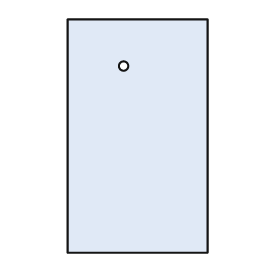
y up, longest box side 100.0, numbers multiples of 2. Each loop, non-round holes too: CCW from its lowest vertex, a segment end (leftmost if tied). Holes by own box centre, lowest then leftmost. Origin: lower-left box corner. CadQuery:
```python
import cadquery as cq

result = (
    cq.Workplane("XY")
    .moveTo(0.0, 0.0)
    .lineTo(60.0, 0.0)
    .lineTo(60.0, 100.0)
    .lineTo(0.0, 100.0)
    .close()
    .moveTo(24.0, 80.0)
    .circle(2.0)
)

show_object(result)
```